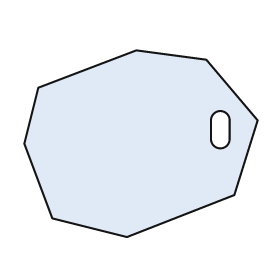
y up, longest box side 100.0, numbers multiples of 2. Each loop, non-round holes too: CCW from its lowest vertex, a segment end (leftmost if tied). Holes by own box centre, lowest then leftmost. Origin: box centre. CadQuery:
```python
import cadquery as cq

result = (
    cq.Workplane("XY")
    .moveTo(-6.0, -40.0)
    .lineTo(40.0, -22.0)
    .lineTo(50.0, 10.0)
    .lineTo(28.0, 36.0)
    .lineTo(-2.0, 40.0)
    .lineTo(-44.0, 24.0)
    .lineTo(-50.0, 0.0)
    .lineTo(-38.0, -32.0)
    .close()
    .moveTo(30.0, 2.0)
    .threePointArc((34.0, -2.0), (38.0, 2.0))
    .lineTo(38.0, 10.0)
    .threePointArc((34.0, 14.0), (30.0, 10.0))
    .close()
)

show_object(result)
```